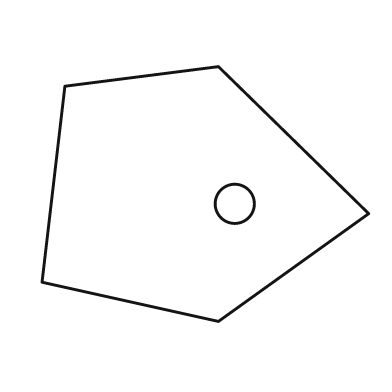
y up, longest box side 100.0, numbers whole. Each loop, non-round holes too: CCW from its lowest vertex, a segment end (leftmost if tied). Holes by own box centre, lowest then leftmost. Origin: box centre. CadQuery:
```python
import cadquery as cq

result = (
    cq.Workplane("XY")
    .moveTo(4.0, -39.0)
    .lineTo(50.0, -6.0)
    .lineTo(4.0, 39.0)
    .lineTo(-43.0, 33.0)
    .lineTo(-50.0, -27.0)
    .close()
    .moveTo(9.0, -3.0)
    .circle(6.0)
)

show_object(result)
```